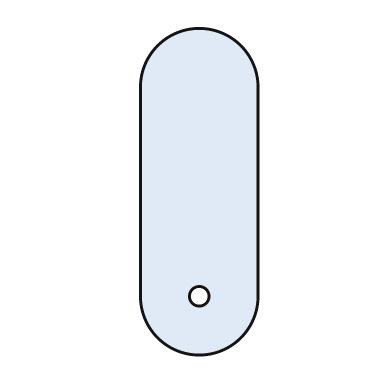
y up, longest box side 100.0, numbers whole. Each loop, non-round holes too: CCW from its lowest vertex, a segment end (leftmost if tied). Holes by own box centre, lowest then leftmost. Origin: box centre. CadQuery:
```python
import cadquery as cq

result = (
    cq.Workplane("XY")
    .moveTo(-18.0, -32.0)
    .threePointArc((0.0, -50.0), (18.0, -32.0))
    .lineTo(18.0, 32.0)
    .threePointArc((0.0, 50.0), (-18.0, 32.0))
    .close()
    .moveTo(0.0, -32.0)
    .circle(3.0)
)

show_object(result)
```